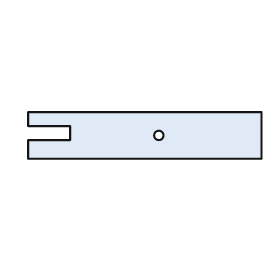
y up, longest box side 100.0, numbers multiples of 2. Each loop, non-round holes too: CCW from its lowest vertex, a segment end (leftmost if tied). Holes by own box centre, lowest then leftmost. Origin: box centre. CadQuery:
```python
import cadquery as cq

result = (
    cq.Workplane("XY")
    .moveTo(-50.0, -10.0)
    .lineTo(50.0, -10.0)
    .lineTo(50.0, 10.0)
    .lineTo(-50.0, 10.0)
    .lineTo(-50.0, 4.0)
    .lineTo(-32.0, 4.0)
    .lineTo(-32.0, -2.0)
    .lineTo(-50.0, -2.0)
    .close()
    .moveTo(6.0, 0.0)
    .circle(2.0)
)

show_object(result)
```